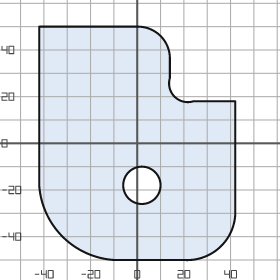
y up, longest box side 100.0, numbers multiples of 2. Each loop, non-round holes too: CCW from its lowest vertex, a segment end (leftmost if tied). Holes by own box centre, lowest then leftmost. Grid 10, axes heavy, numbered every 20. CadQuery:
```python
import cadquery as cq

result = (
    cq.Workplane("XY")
    .moveTo(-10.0, -50.0)
    .lineTo(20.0, -50.0)
    .threePointArc((36.0, -44.0), (42.0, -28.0))
    .lineTo(42.0, 18.0)
    .lineTo(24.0, 18.0)
    .threePointArc((16.0, 20.0), (14.0, 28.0))
    .lineTo(14.0, 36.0)
    .threePointArc((10.0, 46.0), (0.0, 50.0))
    .lineTo(-42.0, 50.0)
    .lineTo(-42.0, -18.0)
    .threePointArc((-32.0, -40.0), (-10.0, -50.0))
    .close()
    .moveTo(2.0, -18.0)
    .circle(8.0)
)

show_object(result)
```